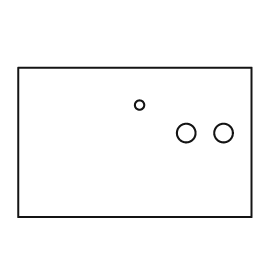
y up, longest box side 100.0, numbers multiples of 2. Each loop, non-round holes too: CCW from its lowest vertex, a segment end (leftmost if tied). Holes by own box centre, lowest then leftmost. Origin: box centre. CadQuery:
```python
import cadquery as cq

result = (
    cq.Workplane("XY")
    .moveTo(-50.0, -32.0)
    .lineTo(50.0, -32.0)
    .lineTo(50.0, 32.0)
    .lineTo(-50.0, 32.0)
    .close()
    .moveTo(22.0, 4.0)
    .circle(4.0)
    .moveTo(38.0, 4.0)
    .circle(4.0)
    .moveTo(2.0, 16.0)
    .circle(2.0)
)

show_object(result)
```